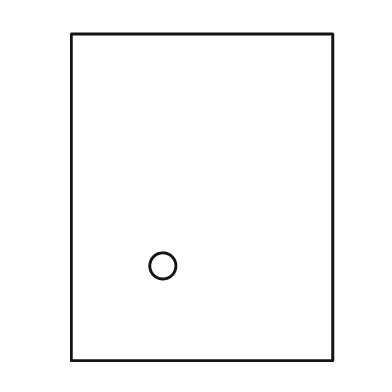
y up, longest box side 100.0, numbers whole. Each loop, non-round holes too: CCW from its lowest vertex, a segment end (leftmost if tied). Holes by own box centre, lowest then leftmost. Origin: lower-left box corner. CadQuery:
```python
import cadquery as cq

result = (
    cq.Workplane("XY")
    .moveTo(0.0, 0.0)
    .lineTo(80.0, 0.0)
    .lineTo(80.0, 100.0)
    .lineTo(0.0, 100.0)
    .close()
    .moveTo(28.0, 29.0)
    .circle(4.0)
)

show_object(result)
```